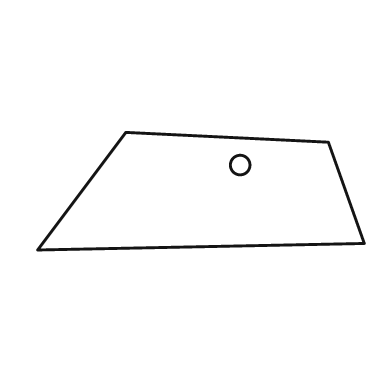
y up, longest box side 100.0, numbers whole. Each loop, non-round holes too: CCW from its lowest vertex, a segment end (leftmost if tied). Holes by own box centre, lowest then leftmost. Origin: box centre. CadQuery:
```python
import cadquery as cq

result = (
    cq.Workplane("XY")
    .moveTo(-50.0, -18.0)
    .lineTo(50.0, -16.0)
    .lineTo(39.0, 15.0)
    .lineTo(-23.0, 18.0)
    .close()
    .moveTo(12.0, 8.0)
    .circle(3.0)
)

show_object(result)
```